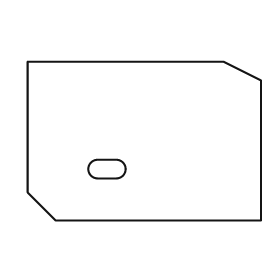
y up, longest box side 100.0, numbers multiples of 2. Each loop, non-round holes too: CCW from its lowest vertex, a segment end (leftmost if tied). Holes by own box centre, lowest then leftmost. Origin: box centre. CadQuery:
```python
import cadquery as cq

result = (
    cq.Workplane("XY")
    .moveTo(-38.0, -34.0)
    .lineTo(50.0, -34.0)
    .lineTo(50.0, 26.0)
    .lineTo(34.0, 34.0)
    .lineTo(-50.0, 34.0)
    .lineTo(-50.0, -22.0)
    .close()
    .moveTo(-20.0, -16.0)
    .lineTo(-12.0, -16.0)
    .threePointArc((-8.0, -12.0), (-12.0, -8.0))
    .lineTo(-20.0, -8.0)
    .threePointArc((-24.0, -12.0), (-20.0, -16.0))
    .close()
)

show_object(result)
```